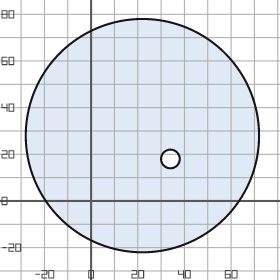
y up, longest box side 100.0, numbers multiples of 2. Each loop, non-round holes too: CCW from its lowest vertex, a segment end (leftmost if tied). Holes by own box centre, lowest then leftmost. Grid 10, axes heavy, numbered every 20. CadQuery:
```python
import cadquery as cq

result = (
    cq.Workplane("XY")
    .moveTo(22.0, 28.0)
    .circle(50.0)
    .moveTo(34.0, 18.0)
    .circle(4.0)
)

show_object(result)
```